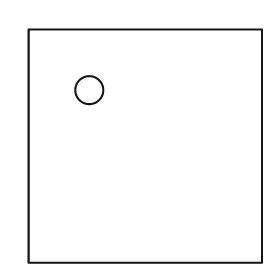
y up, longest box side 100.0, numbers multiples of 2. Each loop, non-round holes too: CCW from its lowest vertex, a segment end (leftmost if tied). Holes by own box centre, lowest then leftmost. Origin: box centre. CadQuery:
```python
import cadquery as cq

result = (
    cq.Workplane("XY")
    .moveTo(-50.0, -50.0)
    .lineTo(50.0, -50.0)
    .lineTo(50.0, 50.0)
    .lineTo(-50.0, 50.0)
    .close()
    .moveTo(-24.0, 24.0)
    .circle(6.0)
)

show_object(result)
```